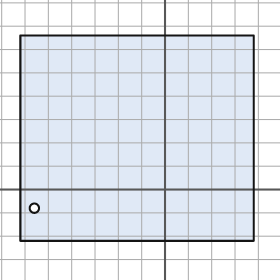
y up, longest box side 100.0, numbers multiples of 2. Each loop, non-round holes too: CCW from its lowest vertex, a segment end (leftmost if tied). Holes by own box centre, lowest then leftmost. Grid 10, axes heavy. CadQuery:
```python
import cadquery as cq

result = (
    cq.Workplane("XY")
    .moveTo(-62.0, -22.0)
    .lineTo(38.0, -22.0)
    .lineTo(38.0, 66.0)
    .lineTo(-62.0, 66.0)
    .close()
    .moveTo(-56.0, -8.0)
    .circle(2.0)
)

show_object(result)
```